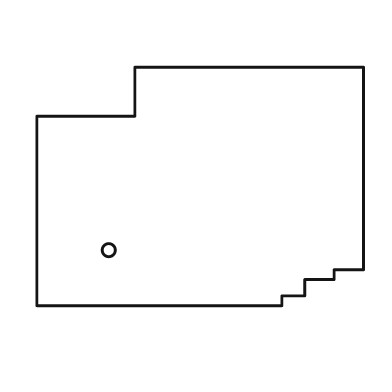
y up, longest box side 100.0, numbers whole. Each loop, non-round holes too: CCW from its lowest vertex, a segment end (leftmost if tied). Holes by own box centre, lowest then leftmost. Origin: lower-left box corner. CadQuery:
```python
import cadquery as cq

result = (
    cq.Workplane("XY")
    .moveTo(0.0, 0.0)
    .lineTo(75.0, 0.0)
    .lineTo(75.0, 3.0)
    .lineTo(82.0, 3.0)
    .lineTo(82.0, 8.0)
    .lineTo(91.0, 8.0)
    .lineTo(91.0, 11.0)
    .lineTo(100.0, 11.0)
    .lineTo(100.0, 73.0)
    .lineTo(30.0, 73.0)
    .lineTo(30.0, 58.0)
    .lineTo(0.0, 58.0)
    .close()
    .moveTo(22.0, 17.0)
    .circle(2.0)
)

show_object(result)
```